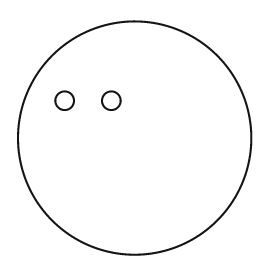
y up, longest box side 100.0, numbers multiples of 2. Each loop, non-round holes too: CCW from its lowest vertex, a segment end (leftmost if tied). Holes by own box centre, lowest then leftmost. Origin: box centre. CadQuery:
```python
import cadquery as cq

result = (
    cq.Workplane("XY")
    .moveTo(0.0, 0.0)
    .circle(50.0)
    .moveTo(-30.0, 16.0)
    .circle(4.0)
    .moveTo(-10.0, 16.0)
    .circle(4.0)
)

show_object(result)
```